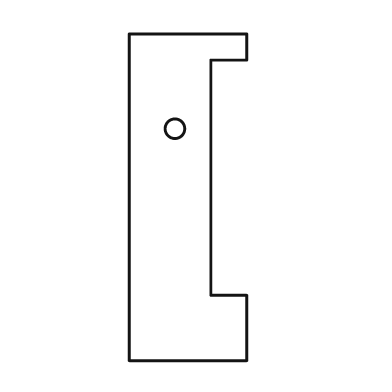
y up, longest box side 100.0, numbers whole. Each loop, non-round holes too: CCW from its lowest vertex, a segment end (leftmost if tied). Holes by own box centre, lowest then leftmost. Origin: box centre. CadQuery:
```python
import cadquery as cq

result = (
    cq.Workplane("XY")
    .moveTo(-18.0, -50.0)
    .lineTo(18.0, -50.0)
    .lineTo(18.0, -30.0)
    .lineTo(7.0, -30.0)
    .lineTo(7.0, 42.0)
    .lineTo(18.0, 42.0)
    .lineTo(18.0, 50.0)
    .lineTo(-18.0, 50.0)
    .close()
    .moveTo(-4.0, 21.0)
    .circle(3.0)
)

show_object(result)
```